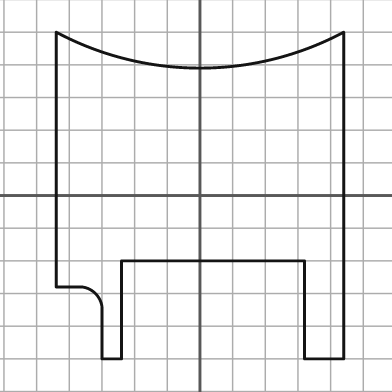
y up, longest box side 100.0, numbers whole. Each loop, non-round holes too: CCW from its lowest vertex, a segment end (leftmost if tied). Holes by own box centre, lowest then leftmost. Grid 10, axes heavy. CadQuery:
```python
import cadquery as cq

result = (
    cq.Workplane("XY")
    .moveTo(-30.0, -50.0)
    .lineTo(-24.0, -50.0)
    .lineTo(-24.0, -20.0)
    .lineTo(32.0, -20.0)
    .lineTo(32.0, -50.0)
    .lineTo(44.0, -50.0)
    .lineTo(44.0, 50.0)
    .threePointArc((0.0, 39.0), (-44.0, 50.0))
    .lineTo(-44.0, -28.0)
    .lineTo(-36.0, -28.0)
    .threePointArc((-32.0, -30.0), (-30.0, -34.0))
    .close()
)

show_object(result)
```